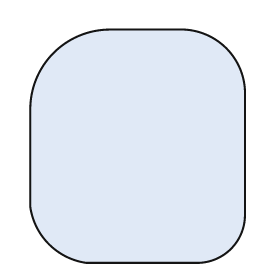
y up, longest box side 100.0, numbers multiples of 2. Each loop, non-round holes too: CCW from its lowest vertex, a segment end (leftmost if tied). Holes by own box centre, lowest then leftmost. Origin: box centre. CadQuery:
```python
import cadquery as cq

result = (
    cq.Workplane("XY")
    .moveTo(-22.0, -50.0)
    .lineTo(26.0, -50.0)
    .threePointArc((40.0, -44.0), (46.0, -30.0))
    .lineTo(46.0, 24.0)
    .threePointArc((38.0, 42.0), (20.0, 50.0))
    .lineTo(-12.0, 50.0)
    .threePointArc((-36.0, 40.0), (-46.0, 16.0))
    .lineTo(-46.0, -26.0)
    .threePointArc((-38.0, -42.0), (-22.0, -50.0))
    .close()
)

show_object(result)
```